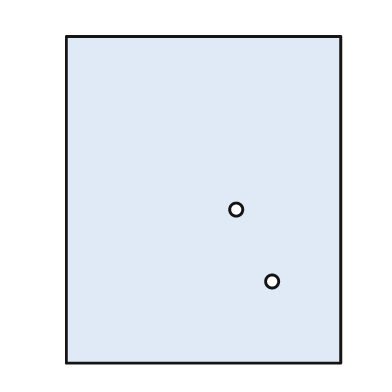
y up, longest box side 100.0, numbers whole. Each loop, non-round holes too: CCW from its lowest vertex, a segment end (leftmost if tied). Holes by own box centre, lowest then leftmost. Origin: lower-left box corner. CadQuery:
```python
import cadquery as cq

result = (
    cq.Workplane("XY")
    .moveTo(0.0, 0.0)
    .lineTo(84.0, 0.0)
    .lineTo(84.0, 100.0)
    .lineTo(0.0, 100.0)
    .close()
    .moveTo(63.0, 25.0)
    .circle(2.0)
    .moveTo(52.0, 47.0)
    .circle(2.0)
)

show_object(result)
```